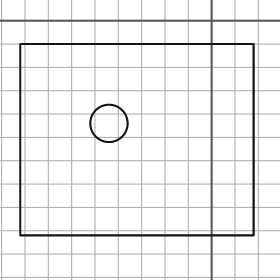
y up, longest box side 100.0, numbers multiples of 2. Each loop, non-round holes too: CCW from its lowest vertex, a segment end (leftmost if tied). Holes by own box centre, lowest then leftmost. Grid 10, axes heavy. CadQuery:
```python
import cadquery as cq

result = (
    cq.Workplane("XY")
    .moveTo(-82.0, -92.0)
    .lineTo(18.0, -92.0)
    .lineTo(18.0, -10.0)
    .lineTo(-82.0, -10.0)
    .close()
    .moveTo(-44.0, -44.0)
    .circle(8.0)
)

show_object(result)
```